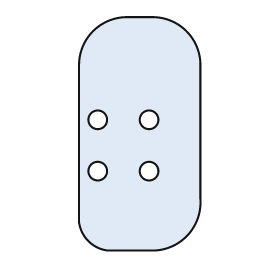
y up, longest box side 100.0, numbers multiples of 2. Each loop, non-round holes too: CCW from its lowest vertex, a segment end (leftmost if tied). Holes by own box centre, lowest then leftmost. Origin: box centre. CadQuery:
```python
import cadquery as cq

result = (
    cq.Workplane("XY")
    .moveTo(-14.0, -50.0)
    .lineTo(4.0, -50.0)
    .threePointArc((20.0, -44.0), (26.0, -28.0))
    .lineTo(26.0, 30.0)
    .threePointArc((20.0, 44.0), (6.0, 50.0))
    .lineTo(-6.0, 50.0)
    .threePointArc((-20.0, 44.0), (-26.0, 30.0))
    .lineTo(-26.0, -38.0)
    .threePointArc((-22.0, -46.0), (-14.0, -50.0))
    .close()
    .moveTo(-18.0, -16.0)
    .circle(4.0)
    .moveTo(4.0, -16.0)
    .circle(4.0)
    .moveTo(-18.0, 6.0)
    .circle(4.0)
    .moveTo(4.0, 6.0)
    .circle(4.0)
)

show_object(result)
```